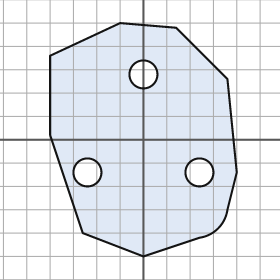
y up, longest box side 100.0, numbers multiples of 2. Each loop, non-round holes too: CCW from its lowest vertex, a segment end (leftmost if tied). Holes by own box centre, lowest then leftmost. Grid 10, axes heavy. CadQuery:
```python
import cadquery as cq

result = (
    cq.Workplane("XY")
    .moveTo(0.0, -50.0)
    .lineTo(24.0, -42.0)
    .threePointArc((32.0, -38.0), (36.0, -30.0))
    .lineTo(40.0, -14.0)
    .lineTo(36.0, 26.0)
    .lineTo(14.0, 48.0)
    .lineTo(-10.0, 50.0)
    .lineTo(-40.0, 36.0)
    .lineTo(-40.0, 2.0)
    .lineTo(-26.0, -40.0)
    .close()
    .moveTo(-24.0, -14.0)
    .circle(6.0)
    .moveTo(24.0, -14.0)
    .circle(6.0)
    .moveTo(0.0, 28.0)
    .circle(6.0)
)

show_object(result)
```